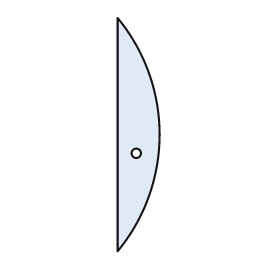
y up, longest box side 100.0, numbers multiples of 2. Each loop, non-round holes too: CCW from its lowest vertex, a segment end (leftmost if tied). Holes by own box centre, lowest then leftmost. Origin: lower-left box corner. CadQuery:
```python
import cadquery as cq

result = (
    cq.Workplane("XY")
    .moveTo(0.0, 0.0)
    .threePointArc((18.0, 50.0), (0.0, 100.0))
    .close()
    .moveTo(8.0, 42.0)
    .circle(2.0)
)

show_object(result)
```